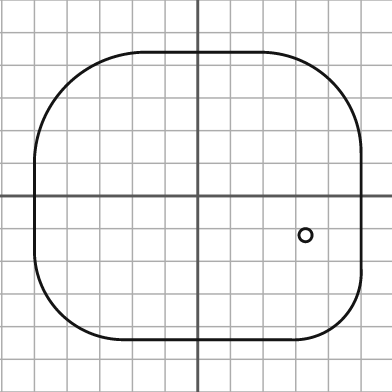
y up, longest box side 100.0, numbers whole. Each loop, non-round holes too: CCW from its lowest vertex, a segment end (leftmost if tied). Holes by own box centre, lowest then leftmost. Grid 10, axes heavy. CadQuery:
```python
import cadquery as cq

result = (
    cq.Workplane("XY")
    .moveTo(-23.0, -44.0)
    .lineTo(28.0, -44.0)
    .threePointArc((44.0, -38.0), (50.0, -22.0))
    .lineTo(50.0, 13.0)
    .threePointArc((41.0, 35.0), (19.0, 44.0))
    .lineTo(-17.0, 44.0)
    .threePointArc((-40.0, 34.0), (-50.0, 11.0))
    .lineTo(-50.0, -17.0)
    .threePointArc((-42.0, -36.0), (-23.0, -44.0))
    .close()
    .moveTo(33.0, -12.0)
    .circle(2.0)
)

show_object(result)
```